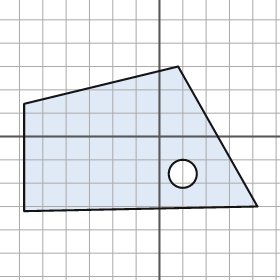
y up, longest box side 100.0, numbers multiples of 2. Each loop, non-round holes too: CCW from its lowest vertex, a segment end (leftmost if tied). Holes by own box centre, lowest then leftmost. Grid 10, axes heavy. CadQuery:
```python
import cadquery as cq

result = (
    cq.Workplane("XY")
    .moveTo(-58.0, -32.0)
    .lineTo(42.0, -30.0)
    .lineTo(8.0, 30.0)
    .lineTo(-58.0, 14.0)
    .close()
    .moveTo(10.0, -16.0)
    .circle(6.0)
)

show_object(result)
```